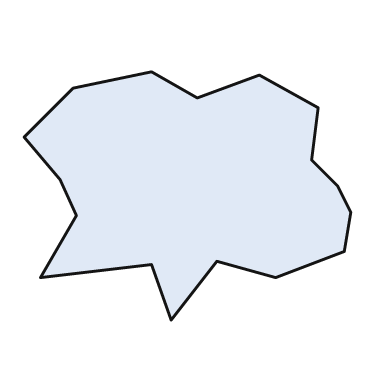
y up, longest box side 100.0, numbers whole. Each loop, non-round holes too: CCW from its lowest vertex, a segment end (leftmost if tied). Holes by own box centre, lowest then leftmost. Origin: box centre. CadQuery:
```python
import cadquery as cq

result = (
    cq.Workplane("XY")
    .moveTo(-5.0, -38.0)
    .lineTo(9.0, -20.0)
    .lineTo(27.0, -25.0)
    .lineTo(48.0, -17.0)
    .lineTo(50.0, -5.0)
    .lineTo(46.0, 3.0)
    .lineTo(38.0, 11.0)
    .lineTo(40.0, 27.0)
    .lineTo(22.0, 37.0)
    .lineTo(3.0, 30.0)
    .lineTo(-11.0, 38.0)
    .lineTo(-35.0, 33.0)
    .lineTo(-50.0, 18.0)
    .lineTo(-39.0, 5.0)
    .lineTo(-34.0, -6.0)
    .lineTo(-45.0, -25.0)
    .lineTo(-11.0, -21.0)
    .close()
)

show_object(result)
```